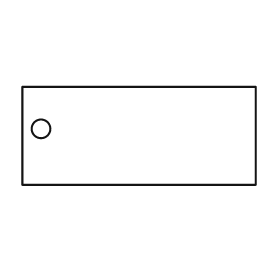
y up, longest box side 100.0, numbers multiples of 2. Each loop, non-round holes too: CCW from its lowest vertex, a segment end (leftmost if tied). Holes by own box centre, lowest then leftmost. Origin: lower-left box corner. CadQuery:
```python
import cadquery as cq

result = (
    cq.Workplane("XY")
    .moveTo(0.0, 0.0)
    .lineTo(100.0, 0.0)
    .lineTo(100.0, 42.0)
    .lineTo(0.0, 42.0)
    .close()
    .moveTo(8.0, 24.0)
    .circle(4.0)
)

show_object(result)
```